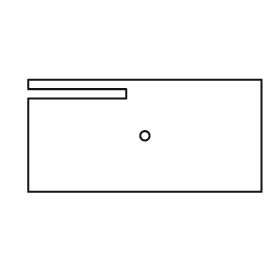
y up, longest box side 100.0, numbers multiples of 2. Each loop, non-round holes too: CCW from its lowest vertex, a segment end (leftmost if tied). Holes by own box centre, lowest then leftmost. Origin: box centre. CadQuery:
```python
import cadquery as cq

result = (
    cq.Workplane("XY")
    .moveTo(-50.0, -24.0)
    .lineTo(50.0, -24.0)
    .lineTo(50.0, 24.0)
    .lineTo(-50.0, 24.0)
    .lineTo(-50.0, 20.0)
    .lineTo(-8.0, 20.0)
    .lineTo(-8.0, 16.0)
    .lineTo(-50.0, 16.0)
    .close()
    .moveTo(0.0, 0.0)
    .circle(2.0)
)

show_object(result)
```